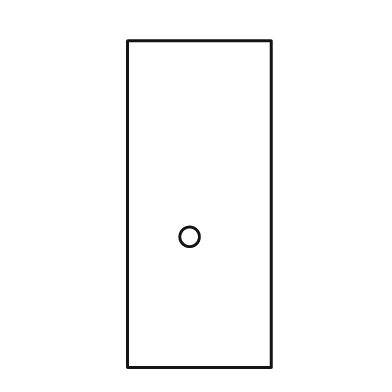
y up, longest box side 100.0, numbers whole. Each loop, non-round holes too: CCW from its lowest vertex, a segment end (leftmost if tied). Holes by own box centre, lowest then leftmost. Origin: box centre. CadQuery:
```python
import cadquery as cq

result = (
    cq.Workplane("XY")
    .moveTo(-22.0, -50.0)
    .lineTo(22.0, -50.0)
    .lineTo(22.0, 50.0)
    .lineTo(-22.0, 50.0)
    .close()
    .moveTo(-3.0, -10.0)
    .circle(3.0)
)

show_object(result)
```